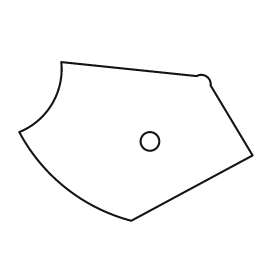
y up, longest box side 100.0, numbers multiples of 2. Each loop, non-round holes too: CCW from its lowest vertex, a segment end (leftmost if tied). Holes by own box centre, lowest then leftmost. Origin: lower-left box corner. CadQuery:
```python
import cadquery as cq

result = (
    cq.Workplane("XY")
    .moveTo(48.0, 0.0)
    .lineTo(100.0, 28.0)
    .lineTo(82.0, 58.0)
    .threePointArc((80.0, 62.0), (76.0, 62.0))
    .lineTo(18.0, 68.0)
    .threePointArc((14.0, 50.0), (0.0, 38.0))
    .threePointArc((20.0, 14.0), (48.0, 0.0))
    .close()
    .moveTo(56.0, 34.0)
    .circle(4.0)
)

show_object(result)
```